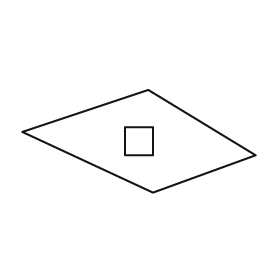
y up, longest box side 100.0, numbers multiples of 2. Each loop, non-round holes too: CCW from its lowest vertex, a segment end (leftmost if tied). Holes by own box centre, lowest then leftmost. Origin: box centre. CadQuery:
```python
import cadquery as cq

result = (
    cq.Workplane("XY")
    .moveTo(6.0, -22.0)
    .lineTo(50.0, -6.0)
    .lineTo(4.0, 22.0)
    .lineTo(-50.0, 4.0)
    .close()
    .moveTo(-6.0, -6.0)
    .lineTo(6.0, -6.0)
    .lineTo(6.0, 6.0)
    .lineTo(-6.0, 6.0)
    .close()
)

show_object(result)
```